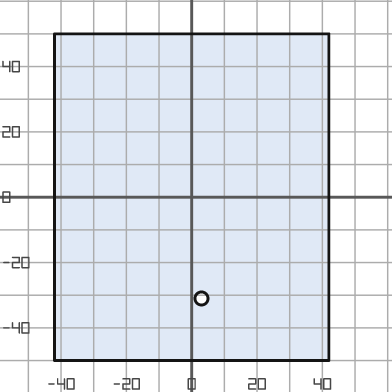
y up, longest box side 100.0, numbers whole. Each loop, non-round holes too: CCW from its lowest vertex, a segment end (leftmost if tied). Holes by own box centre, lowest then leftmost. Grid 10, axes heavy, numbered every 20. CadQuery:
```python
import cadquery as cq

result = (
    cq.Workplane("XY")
    .moveTo(-42.0, -50.0)
    .lineTo(42.0, -50.0)
    .lineTo(42.0, 50.0)
    .lineTo(-42.0, 50.0)
    .close()
    .moveTo(3.0, -31.0)
    .circle(2.0)
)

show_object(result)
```